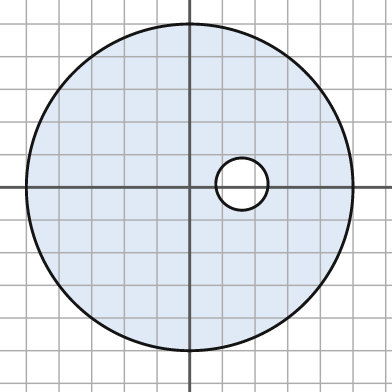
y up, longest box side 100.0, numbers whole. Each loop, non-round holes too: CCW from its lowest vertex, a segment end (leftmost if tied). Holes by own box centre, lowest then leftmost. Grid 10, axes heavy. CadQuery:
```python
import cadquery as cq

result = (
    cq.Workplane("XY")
    .moveTo(0.0, 0.0)
    .circle(50.0)
    .moveTo(16.0, 1.0)
    .circle(8.0)
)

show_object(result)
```